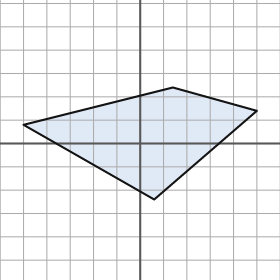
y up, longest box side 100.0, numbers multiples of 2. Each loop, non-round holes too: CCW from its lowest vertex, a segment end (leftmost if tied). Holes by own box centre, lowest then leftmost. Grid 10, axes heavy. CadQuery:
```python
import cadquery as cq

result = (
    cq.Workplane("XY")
    .moveTo(6.0, -24.0)
    .lineTo(50.0, 14.0)
    .lineTo(14.0, 24.0)
    .lineTo(-50.0, 8.0)
    .close()
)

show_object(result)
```